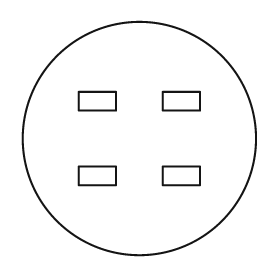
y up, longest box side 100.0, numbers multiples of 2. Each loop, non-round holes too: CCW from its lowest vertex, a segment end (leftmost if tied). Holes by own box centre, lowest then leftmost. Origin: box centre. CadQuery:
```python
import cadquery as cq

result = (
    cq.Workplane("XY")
    .moveTo(0.0, 0.0)
    .circle(50.0)
    .moveTo(-26.0, -20.0)
    .lineTo(-10.0, -20.0)
    .lineTo(-10.0, -12.0)
    .lineTo(-26.0, -12.0)
    .close()
    .moveTo(10.0, -20.0)
    .lineTo(26.0, -20.0)
    .lineTo(26.0, -12.0)
    .lineTo(10.0, -12.0)
    .close()
    .moveTo(-26.0, 12.0)
    .lineTo(-10.0, 12.0)
    .lineTo(-10.0, 20.0)
    .lineTo(-26.0, 20.0)
    .close()
    .moveTo(10.0, 12.0)
    .lineTo(26.0, 12.0)
    .lineTo(26.0, 20.0)
    .lineTo(10.0, 20.0)
    .close()
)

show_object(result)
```